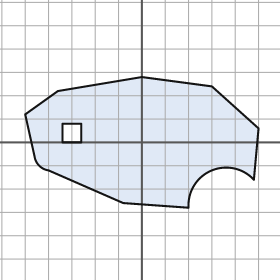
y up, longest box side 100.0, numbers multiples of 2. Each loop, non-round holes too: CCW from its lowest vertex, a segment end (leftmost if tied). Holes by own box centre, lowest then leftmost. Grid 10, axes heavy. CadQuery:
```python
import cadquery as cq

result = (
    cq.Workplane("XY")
    .moveTo(20.0, -28.0)
    .threePointArc((30.0, -12.0), (48.0, -16.0))
    .lineTo(50.0, 6.0)
    .lineTo(30.0, 24.0)
    .lineTo(0.0, 28.0)
    .lineTo(-36.0, 22.0)
    .lineTo(-50.0, 12.0)
    .lineTo(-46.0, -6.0)
    .threePointArc((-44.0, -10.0), (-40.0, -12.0))
    .lineTo(-8.0, -26.0)
    .close()
    .moveTo(-34.0, 0.0)
    .lineTo(-26.0, 0.0)
    .lineTo(-26.0, 8.0)
    .lineTo(-34.0, 8.0)
    .close()
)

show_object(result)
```